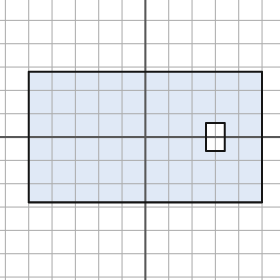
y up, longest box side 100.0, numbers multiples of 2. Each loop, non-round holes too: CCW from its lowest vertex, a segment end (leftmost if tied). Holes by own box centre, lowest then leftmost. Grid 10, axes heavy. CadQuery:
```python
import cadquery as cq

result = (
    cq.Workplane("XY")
    .moveTo(-50.0, -28.0)
    .lineTo(50.0, -28.0)
    .lineTo(50.0, 28.0)
    .lineTo(-50.0, 28.0)
    .close()
    .moveTo(26.0, -6.0)
    .lineTo(34.0, -6.0)
    .lineTo(34.0, 6.0)
    .lineTo(26.0, 6.0)
    .close()
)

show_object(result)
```